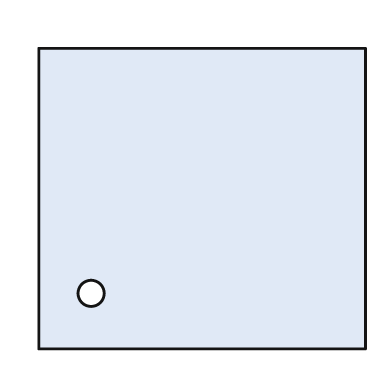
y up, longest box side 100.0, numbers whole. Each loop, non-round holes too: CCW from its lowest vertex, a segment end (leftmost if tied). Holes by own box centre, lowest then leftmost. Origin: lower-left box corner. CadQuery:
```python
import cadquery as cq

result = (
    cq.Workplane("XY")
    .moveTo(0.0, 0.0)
    .lineTo(100.0, 0.0)
    .lineTo(100.0, 92.0)
    .lineTo(0.0, 92.0)
    .close()
    .moveTo(16.0, 17.0)
    .circle(4.0)
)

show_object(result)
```